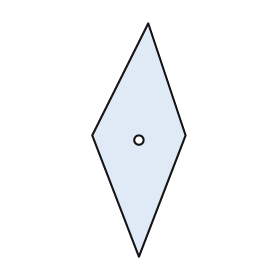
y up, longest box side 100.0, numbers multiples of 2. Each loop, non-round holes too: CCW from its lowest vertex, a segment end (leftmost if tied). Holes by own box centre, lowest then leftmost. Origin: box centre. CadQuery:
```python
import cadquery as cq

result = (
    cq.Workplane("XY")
    .moveTo(0.0, -50.0)
    .lineTo(20.0, 2.0)
    .lineTo(4.0, 50.0)
    .lineTo(-20.0, 2.0)
    .close()
    .moveTo(0.0, 0.0)
    .circle(2.0)
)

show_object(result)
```